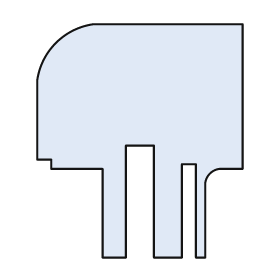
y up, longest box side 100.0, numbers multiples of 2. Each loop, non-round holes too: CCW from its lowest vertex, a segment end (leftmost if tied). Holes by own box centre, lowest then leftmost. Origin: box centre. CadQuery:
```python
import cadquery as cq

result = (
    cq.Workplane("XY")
    .moveTo(-16.0, -50.0)
    .lineTo(-6.0, -50.0)
    .lineTo(-6.0, -2.0)
    .lineTo(6.0, -2.0)
    .lineTo(6.0, -50.0)
    .lineTo(18.0, -50.0)
    .lineTo(18.0, -10.0)
    .lineTo(24.0, -10.0)
    .lineTo(24.0, -50.0)
    .lineTo(28.0, -50.0)
    .lineTo(28.0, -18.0)
    .threePointArc((30.0, -14.0), (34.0, -12.0))
    .lineTo(44.0, -12.0)
    .lineTo(44.0, 50.0)
    .lineTo(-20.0, 50.0)
    .threePointArc((-36.0, 42.0), (-44.0, 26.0))
    .lineTo(-44.0, -8.0)
    .lineTo(-38.0, -8.0)
    .lineTo(-38.0, -12.0)
    .lineTo(-16.0, -12.0)
    .close()
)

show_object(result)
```